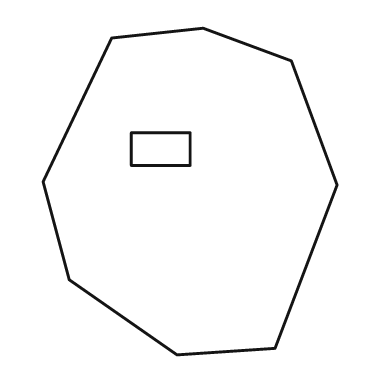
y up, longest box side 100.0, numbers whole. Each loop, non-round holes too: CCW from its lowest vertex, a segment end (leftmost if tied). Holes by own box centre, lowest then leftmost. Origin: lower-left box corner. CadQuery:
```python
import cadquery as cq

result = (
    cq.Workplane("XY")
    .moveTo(41.0, 0.0)
    .lineTo(71.0, 2.0)
    .lineTo(90.0, 52.0)
    .lineTo(76.0, 90.0)
    .lineTo(49.0, 100.0)
    .lineTo(21.0, 97.0)
    .lineTo(0.0, 53.0)
    .lineTo(8.0, 23.0)
    .close()
    .moveTo(27.0, 58.0)
    .lineTo(45.0, 58.0)
    .lineTo(45.0, 68.0)
    .lineTo(27.0, 68.0)
    .close()
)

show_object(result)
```